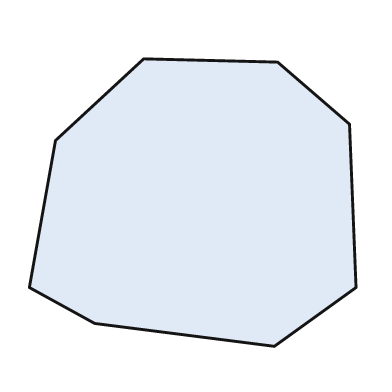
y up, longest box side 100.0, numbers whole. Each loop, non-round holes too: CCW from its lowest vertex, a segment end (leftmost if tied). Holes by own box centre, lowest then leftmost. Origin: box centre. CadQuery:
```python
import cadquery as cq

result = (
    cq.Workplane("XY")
    .moveTo(25.0, -44.0)
    .lineTo(50.0, -26.0)
    .lineTo(48.0, 24.0)
    .lineTo(26.0, 43.0)
    .lineTo(-15.0, 44.0)
    .lineTo(-42.0, 19.0)
    .lineTo(-50.0, -26.0)
    .lineTo(-30.0, -37.0)
    .close()
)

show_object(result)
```